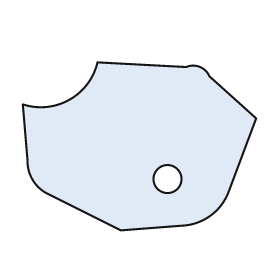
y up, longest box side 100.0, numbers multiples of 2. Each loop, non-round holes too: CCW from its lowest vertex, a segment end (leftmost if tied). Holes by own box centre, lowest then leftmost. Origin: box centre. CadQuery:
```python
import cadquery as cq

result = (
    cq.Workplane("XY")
    .moveTo(-8.0, -36.0)
    .lineTo(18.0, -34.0)
    .threePointArc((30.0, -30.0), (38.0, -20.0))
    .lineTo(50.0, 12.0)
    .lineTo(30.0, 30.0)
    .threePointArc((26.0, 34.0), (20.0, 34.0))
    .lineTo(-18.0, 36.0)
    .threePointArc((-30.0, 20.0), (-50.0, 18.0))
    .lineTo(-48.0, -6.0)
    .threePointArc((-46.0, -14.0), (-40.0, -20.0))
    .close()
    .moveTo(12.0, -14.0)
    .circle(6.0)
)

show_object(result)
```